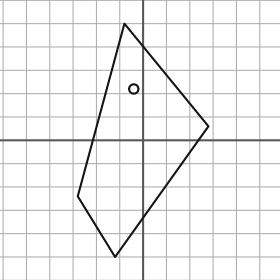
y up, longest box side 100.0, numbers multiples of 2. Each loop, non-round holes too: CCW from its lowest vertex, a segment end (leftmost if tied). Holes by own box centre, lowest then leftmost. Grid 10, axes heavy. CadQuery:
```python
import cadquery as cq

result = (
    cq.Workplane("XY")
    .moveTo(-12.0, -50.0)
    .lineTo(28.0, 6.0)
    .lineTo(-8.0, 50.0)
    .lineTo(-28.0, -24.0)
    .close()
    .moveTo(-4.0, 22.0)
    .circle(2.0)
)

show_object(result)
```